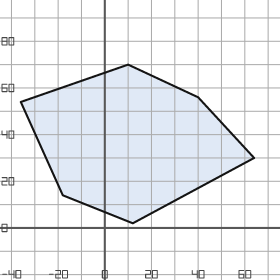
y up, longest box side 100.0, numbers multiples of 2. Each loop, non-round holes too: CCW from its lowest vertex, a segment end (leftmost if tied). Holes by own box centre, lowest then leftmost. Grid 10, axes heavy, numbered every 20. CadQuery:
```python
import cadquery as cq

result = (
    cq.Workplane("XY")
    .moveTo(12.0, 2.0)
    .lineTo(64.0, 30.0)
    .lineTo(40.0, 56.0)
    .lineTo(10.0, 70.0)
    .lineTo(-36.0, 54.0)
    .lineTo(-18.0, 14.0)
    .close()
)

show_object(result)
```